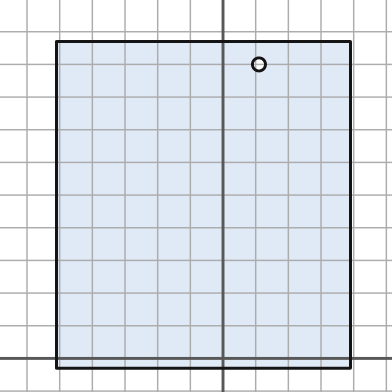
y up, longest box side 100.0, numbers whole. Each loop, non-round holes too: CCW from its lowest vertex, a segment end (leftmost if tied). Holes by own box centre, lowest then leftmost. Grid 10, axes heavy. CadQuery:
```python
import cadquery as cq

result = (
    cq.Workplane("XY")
    .moveTo(-51.0, -3.0)
    .lineTo(39.0, -3.0)
    .lineTo(39.0, 97.0)
    .lineTo(-51.0, 97.0)
    .close()
    .moveTo(11.0, 90.0)
    .circle(2.0)
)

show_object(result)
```